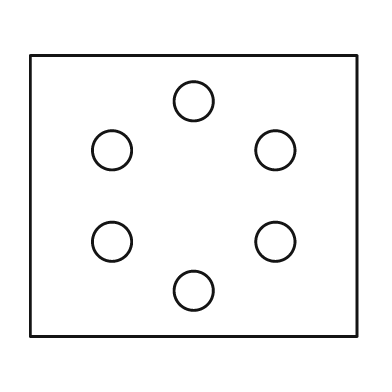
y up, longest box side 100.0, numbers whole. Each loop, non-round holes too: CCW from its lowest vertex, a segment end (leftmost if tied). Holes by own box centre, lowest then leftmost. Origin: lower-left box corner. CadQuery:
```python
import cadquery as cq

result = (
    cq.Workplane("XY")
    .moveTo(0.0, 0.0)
    .lineTo(100.0, 0.0)
    .lineTo(100.0, 86.0)
    .lineTo(0.0, 86.0)
    .close()
    .moveTo(50.0, 14.0)
    .circle(6.0)
    .moveTo(25.0, 29.0)
    .circle(6.0)
    .moveTo(75.0, 29.0)
    .circle(6.0)
    .moveTo(25.0, 57.0)
    .circle(6.0)
    .moveTo(75.0, 57.0)
    .circle(6.0)
    .moveTo(50.0, 72.0)
    .circle(6.0)
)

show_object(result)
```